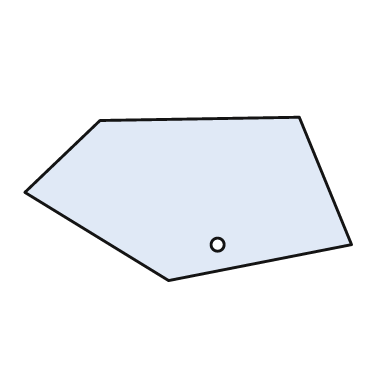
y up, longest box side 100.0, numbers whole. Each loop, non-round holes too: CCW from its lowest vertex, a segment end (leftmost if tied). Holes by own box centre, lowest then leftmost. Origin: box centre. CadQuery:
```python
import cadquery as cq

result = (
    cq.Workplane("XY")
    .moveTo(-6.0, -25.0)
    .lineTo(50.0, -14.0)
    .lineTo(34.0, 25.0)
    .lineTo(-27.0, 24.0)
    .lineTo(-50.0, 2.0)
    .close()
    .moveTo(9.0, -14.0)
    .circle(2.0)
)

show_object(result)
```